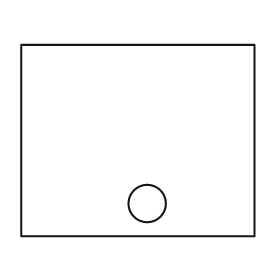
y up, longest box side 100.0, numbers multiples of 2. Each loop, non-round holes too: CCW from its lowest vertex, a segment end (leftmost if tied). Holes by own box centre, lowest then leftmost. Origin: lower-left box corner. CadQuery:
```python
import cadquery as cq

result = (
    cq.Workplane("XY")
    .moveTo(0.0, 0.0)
    .lineTo(100.0, 0.0)
    .lineTo(100.0, 82.0)
    .lineTo(0.0, 82.0)
    .close()
    .moveTo(54.0, 14.0)
    .circle(8.0)
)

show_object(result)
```